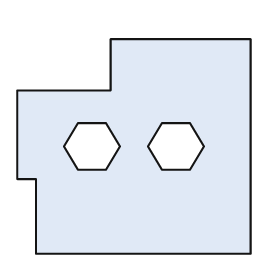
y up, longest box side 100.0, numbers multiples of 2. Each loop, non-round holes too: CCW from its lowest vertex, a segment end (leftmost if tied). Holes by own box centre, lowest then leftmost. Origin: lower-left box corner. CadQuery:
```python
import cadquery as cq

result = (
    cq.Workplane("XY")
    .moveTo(8.0, 0.0)
    .lineTo(100.0, 0.0)
    .lineTo(100.0, 92.0)
    .lineTo(40.0, 92.0)
    .lineTo(40.0, 70.0)
    .lineTo(0.0, 70.0)
    .lineTo(0.0, 32.0)
    .lineTo(8.0, 32.0)
    .close()
    .moveTo(26.0, 36.0)
    .lineTo(38.0, 36.0)
    .lineTo(44.0, 46.0)
    .lineTo(38.0, 56.0)
    .lineTo(26.0, 56.0)
    .lineTo(20.0, 46.0)
    .close()
    .moveTo(62.0, 36.0)
    .lineTo(74.0, 36.0)
    .lineTo(80.0, 46.0)
    .lineTo(74.0, 56.0)
    .lineTo(62.0, 56.0)
    .lineTo(56.0, 46.0)
    .close()
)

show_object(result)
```